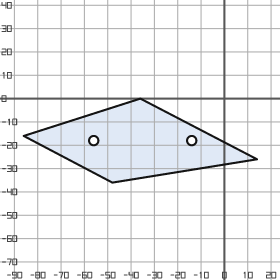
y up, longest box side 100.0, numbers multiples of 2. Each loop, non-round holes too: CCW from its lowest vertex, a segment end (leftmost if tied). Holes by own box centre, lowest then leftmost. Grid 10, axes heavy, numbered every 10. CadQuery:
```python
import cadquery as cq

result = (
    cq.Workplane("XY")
    .moveTo(-48.0, -36.0)
    .lineTo(14.0, -26.0)
    .lineTo(-36.0, 0.0)
    .lineTo(-86.0, -16.0)
    .close()
    .moveTo(-56.0, -18.0)
    .circle(2.0)
    .moveTo(-14.0, -18.0)
    .circle(2.0)
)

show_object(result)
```